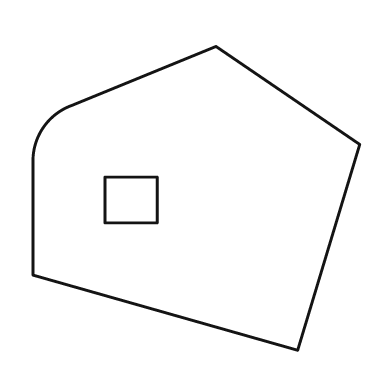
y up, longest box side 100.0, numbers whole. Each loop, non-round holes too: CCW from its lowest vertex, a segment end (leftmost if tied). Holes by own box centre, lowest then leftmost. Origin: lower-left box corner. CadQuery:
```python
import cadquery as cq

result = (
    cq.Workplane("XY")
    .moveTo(81.0, 0.0)
    .lineTo(100.0, 63.0)
    .lineTo(56.0, 93.0)
    .lineTo(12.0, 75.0)
    .threePointArc((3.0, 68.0), (0.0, 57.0))
    .lineTo(0.0, 23.0)
    .close()
    .moveTo(22.0, 39.0)
    .lineTo(38.0, 39.0)
    .lineTo(38.0, 53.0)
    .lineTo(22.0, 53.0)
    .close()
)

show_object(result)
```